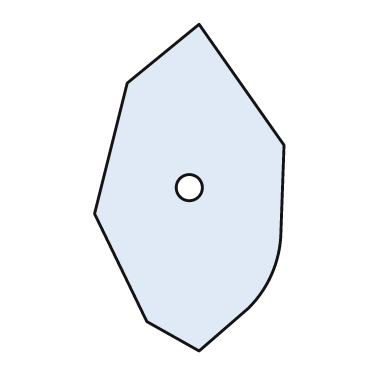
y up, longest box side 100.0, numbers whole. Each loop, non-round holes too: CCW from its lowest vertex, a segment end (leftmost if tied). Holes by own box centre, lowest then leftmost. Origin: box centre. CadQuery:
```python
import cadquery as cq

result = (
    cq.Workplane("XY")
    .moveTo(3.0, -50.0)
    .lineTo(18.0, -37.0)
    .threePointArc((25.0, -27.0), (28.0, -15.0))
    .lineTo(29.0, 13.0)
    .lineTo(3.0, 50.0)
    .lineTo(-19.0, 32.0)
    .lineTo(-29.0, -8.0)
    .lineTo(-13.0, -41.0)
    .close()
    .moveTo(0.0, 0.0)
    .circle(4.0)
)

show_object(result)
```